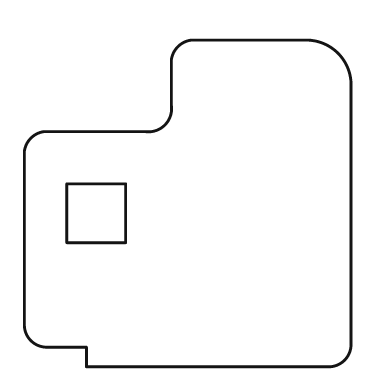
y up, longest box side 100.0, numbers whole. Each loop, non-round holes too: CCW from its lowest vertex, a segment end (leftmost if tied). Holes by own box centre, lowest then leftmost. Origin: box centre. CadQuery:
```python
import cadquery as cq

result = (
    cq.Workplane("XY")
    .moveTo(-31.0, -50.0)
    .lineTo(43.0, -50.0)
    .threePointArc((48.0, -48.0), (50.0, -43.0))
    .lineTo(50.0, 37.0)
    .threePointArc((46.0, 46.0), (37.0, 50.0))
    .lineTo(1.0, 50.0)
    .threePointArc((-3.0, 48.0), (-5.0, 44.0))
    .lineTo(-5.0, 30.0)
    .threePointArc((-7.0, 24.0), (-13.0, 22.0))
    .lineTo(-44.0, 22.0)
    .threePointArc((-48.0, 20.0), (-50.0, 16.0))
    .lineTo(-50.0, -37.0)
    .threePointArc((-48.0, -42.0), (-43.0, -44.0))
    .lineTo(-31.0, -44.0)
    .close()
    .moveTo(-37.0, -12.0)
    .lineTo(-19.0, -12.0)
    .lineTo(-19.0, 6.0)
    .lineTo(-37.0, 6.0)
    .close()
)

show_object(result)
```